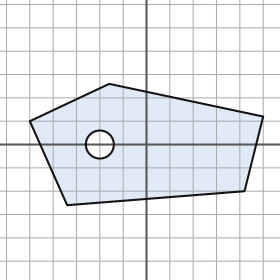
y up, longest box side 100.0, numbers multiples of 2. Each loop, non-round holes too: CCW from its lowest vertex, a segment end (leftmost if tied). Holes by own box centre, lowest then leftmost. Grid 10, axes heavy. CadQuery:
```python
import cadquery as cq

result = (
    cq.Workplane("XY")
    .moveTo(-34.0, -26.0)
    .lineTo(42.0, -20.0)
    .lineTo(50.0, 12.0)
    .lineTo(-16.0, 26.0)
    .lineTo(-50.0, 10.0)
    .close()
    .moveTo(-20.0, 0.0)
    .circle(6.0)
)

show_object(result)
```